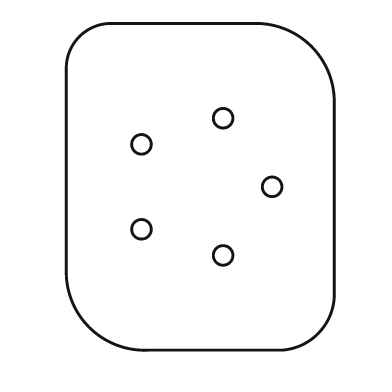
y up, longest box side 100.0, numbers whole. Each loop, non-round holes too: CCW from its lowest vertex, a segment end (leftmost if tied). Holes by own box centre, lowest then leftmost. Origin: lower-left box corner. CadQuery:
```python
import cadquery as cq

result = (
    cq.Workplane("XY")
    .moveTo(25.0, 0.0)
    .lineTo(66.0, 0.0)
    .threePointArc((77.0, 5.0), (82.0, 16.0))
    .lineTo(82.0, 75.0)
    .threePointArc((75.0, 93.0), (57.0, 100.0))
    .lineTo(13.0, 100.0)
    .threePointArc((4.0, 96.0), (0.0, 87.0))
    .lineTo(0.0, 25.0)
    .threePointArc((7.0, 7.0), (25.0, 0.0))
    .close()
    .moveTo(48.0, 29.0)
    .circle(3.0)
    .moveTo(23.0, 37.0)
    .circle(3.0)
    .moveTo(63.0, 50.0)
    .circle(3.0)
    .moveTo(23.0, 63.0)
    .circle(3.0)
    .moveTo(48.0, 71.0)
    .circle(3.0)
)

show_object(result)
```